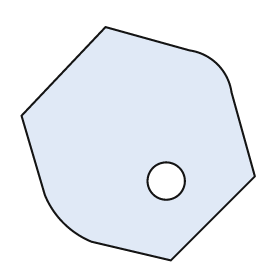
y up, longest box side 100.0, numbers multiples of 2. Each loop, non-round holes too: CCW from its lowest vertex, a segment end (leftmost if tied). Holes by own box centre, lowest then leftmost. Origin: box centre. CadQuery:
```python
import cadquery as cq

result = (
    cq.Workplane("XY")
    .moveTo(14.0, -50.0)
    .lineTo(50.0, -14.0)
    .lineTo(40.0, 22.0)
    .threePointArc((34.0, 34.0), (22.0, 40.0))
    .lineTo(-14.0, 50.0)
    .lineTo(-50.0, 12.0)
    .lineTo(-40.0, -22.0)
    .threePointArc((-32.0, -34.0), (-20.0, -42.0))
    .close()
    .moveTo(12.0, -16.0)
    .circle(8.0)
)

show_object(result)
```